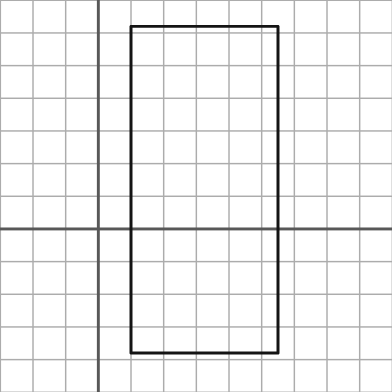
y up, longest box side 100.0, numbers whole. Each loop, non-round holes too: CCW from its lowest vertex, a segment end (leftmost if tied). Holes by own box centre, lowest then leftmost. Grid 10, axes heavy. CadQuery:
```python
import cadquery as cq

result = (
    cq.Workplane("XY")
    .moveTo(10.0, -38.0)
    .lineTo(55.0, -38.0)
    .lineTo(55.0, 62.0)
    .lineTo(10.0, 62.0)
    .close()
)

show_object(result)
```